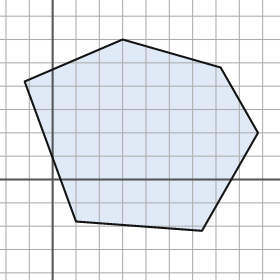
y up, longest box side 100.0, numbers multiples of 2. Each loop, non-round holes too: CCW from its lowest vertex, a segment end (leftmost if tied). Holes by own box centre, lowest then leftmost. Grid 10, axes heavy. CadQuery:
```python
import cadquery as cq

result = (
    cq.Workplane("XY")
    .moveTo(64.0, -22.0)
    .lineTo(88.0, 20.0)
    .lineTo(72.0, 48.0)
    .lineTo(30.0, 60.0)
    .lineTo(-12.0, 42.0)
    .lineTo(10.0, -18.0)
    .close()
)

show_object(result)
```